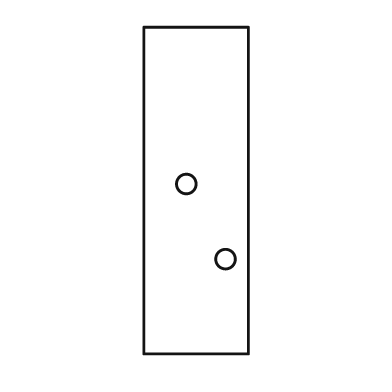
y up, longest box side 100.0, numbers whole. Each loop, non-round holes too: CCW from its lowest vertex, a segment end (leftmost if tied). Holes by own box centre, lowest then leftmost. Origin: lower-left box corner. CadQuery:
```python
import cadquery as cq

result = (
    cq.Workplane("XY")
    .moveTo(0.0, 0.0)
    .lineTo(32.0, 0.0)
    .lineTo(32.0, 100.0)
    .lineTo(0.0, 100.0)
    .close()
    .moveTo(25.0, 29.0)
    .circle(3.0)
    .moveTo(13.0, 52.0)
    .circle(3.0)
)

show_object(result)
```